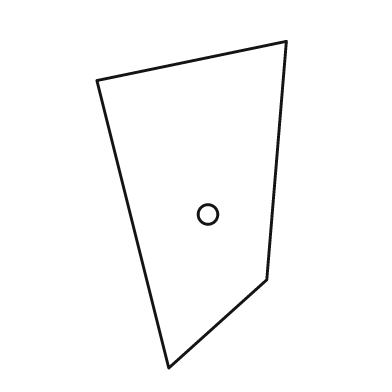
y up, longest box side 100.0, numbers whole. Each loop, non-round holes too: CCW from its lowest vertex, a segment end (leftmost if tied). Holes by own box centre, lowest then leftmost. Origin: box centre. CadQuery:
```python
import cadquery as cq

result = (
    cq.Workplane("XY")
    .moveTo(-7.0, -50.0)
    .lineTo(23.0, -23.0)
    .lineTo(29.0, 50.0)
    .lineTo(-29.0, 38.0)
    .close()
    .moveTo(5.0, -3.0)
    .circle(3.0)
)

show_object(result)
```